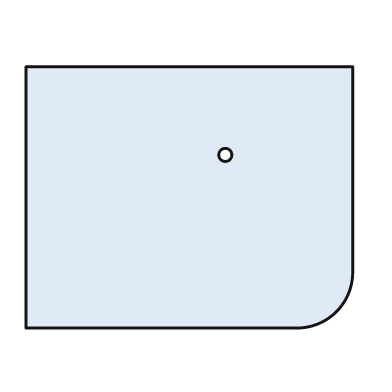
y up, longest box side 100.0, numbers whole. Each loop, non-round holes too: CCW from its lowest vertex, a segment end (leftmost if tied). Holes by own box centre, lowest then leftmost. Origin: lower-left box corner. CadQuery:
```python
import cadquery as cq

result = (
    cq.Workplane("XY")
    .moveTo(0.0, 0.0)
    .lineTo(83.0, 0.0)
    .threePointArc((95.0, 5.0), (100.0, 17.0))
    .lineTo(100.0, 80.0)
    .lineTo(0.0, 80.0)
    .close()
    .moveTo(61.0, 53.0)
    .circle(2.0)
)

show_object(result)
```